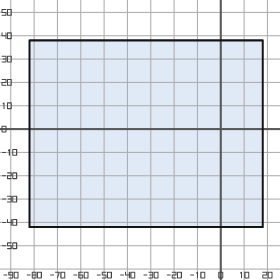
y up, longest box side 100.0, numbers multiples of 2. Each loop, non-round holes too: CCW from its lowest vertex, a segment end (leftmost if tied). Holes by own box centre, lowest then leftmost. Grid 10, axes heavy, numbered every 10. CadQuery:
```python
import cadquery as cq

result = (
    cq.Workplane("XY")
    .moveTo(-82.0, -42.0)
    .lineTo(18.0, -42.0)
    .lineTo(18.0, 38.0)
    .lineTo(-82.0, 38.0)
    .close()
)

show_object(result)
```